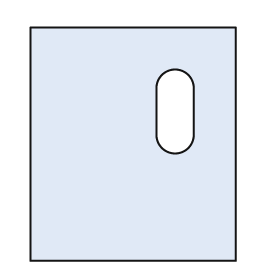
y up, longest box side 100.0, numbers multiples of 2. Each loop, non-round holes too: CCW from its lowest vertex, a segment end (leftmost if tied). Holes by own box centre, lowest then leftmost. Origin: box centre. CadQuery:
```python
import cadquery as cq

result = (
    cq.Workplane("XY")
    .moveTo(-44.0, -50.0)
    .lineTo(44.0, -50.0)
    .lineTo(44.0, 50.0)
    .lineTo(-44.0, 50.0)
    .close()
    .moveTo(10.0, 4.0)
    .threePointArc((18.0, -4.0), (26.0, 4.0))
    .lineTo(26.0, 24.0)
    .threePointArc((18.0, 32.0), (10.0, 24.0))
    .close()
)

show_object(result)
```